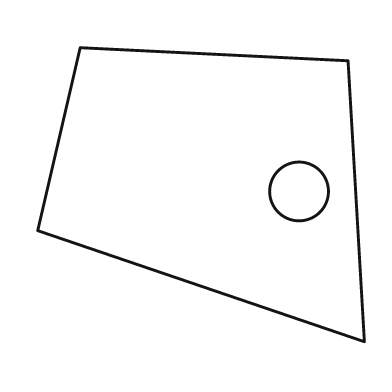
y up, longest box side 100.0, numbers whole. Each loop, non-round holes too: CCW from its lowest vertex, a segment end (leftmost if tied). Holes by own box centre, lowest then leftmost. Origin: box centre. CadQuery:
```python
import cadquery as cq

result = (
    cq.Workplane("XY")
    .moveTo(50.0, -45.0)
    .lineTo(45.0, 41.0)
    .lineTo(-37.0, 45.0)
    .lineTo(-50.0, -11.0)
    .close()
    .moveTo(30.0, 1.0)
    .circle(9.0)
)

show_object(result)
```